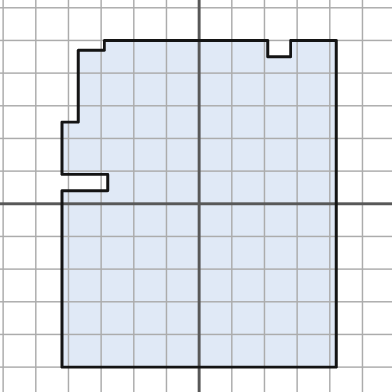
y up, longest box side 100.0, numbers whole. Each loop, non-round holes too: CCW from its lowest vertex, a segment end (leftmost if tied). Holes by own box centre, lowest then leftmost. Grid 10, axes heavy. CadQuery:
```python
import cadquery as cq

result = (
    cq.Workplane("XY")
    .moveTo(-42.0, -50.0)
    .lineTo(42.0, -50.0)
    .lineTo(42.0, 50.0)
    .lineTo(28.0, 50.0)
    .lineTo(28.0, 45.0)
    .lineTo(21.0, 45.0)
    .lineTo(21.0, 50.0)
    .lineTo(-29.0, 50.0)
    .lineTo(-29.0, 47.0)
    .lineTo(-37.0, 47.0)
    .lineTo(-37.0, 25.0)
    .lineTo(-42.0, 25.0)
    .lineTo(-42.0, 9.0)
    .lineTo(-28.0, 9.0)
    .lineTo(-28.0, 4.0)
    .lineTo(-42.0, 4.0)
    .close()
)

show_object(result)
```